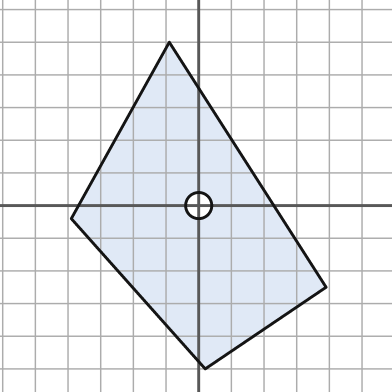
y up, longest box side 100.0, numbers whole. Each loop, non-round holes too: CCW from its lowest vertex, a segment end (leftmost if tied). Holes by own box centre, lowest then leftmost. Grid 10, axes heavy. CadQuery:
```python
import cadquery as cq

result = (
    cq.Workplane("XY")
    .moveTo(2.0, -50.0)
    .lineTo(39.0, -25.0)
    .lineTo(-9.0, 50.0)
    .lineTo(-39.0, -4.0)
    .close()
    .moveTo(0.0, 0.0)
    .circle(4.0)
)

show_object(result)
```